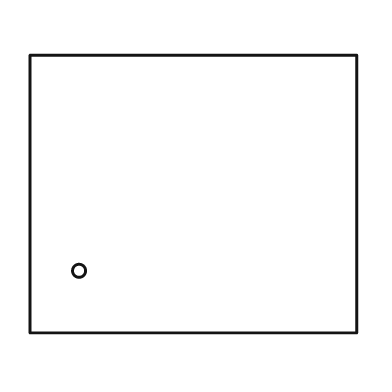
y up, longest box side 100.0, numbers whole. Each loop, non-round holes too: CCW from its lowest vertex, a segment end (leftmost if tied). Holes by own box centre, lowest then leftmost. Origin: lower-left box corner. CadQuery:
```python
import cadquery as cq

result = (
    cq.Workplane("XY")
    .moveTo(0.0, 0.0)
    .lineTo(100.0, 0.0)
    .lineTo(100.0, 85.0)
    .lineTo(0.0, 85.0)
    .close()
    .moveTo(15.0, 19.0)
    .circle(2.0)
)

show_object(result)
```